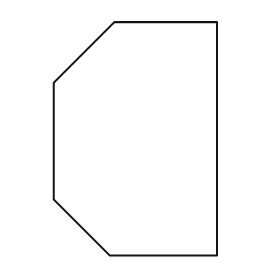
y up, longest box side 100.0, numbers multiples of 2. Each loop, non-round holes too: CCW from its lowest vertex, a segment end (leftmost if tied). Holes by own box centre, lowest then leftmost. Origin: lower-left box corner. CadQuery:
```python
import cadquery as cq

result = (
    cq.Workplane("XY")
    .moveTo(24.0, 0.0)
    .lineTo(70.0, 0.0)
    .lineTo(70.0, 100.0)
    .lineTo(26.0, 100.0)
    .lineTo(0.0, 74.0)
    .lineTo(0.0, 24.0)
    .close()
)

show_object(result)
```